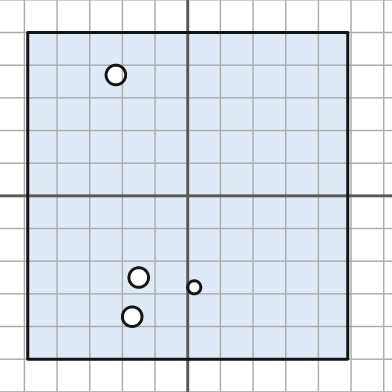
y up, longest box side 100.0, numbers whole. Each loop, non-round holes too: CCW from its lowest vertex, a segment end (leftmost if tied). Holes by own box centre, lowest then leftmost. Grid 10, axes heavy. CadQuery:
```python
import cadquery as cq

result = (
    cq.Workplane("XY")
    .moveTo(-49.0, -50.0)
    .lineTo(49.0, -50.0)
    .lineTo(49.0, 50.0)
    .lineTo(-49.0, 50.0)
    .close()
    .moveTo(-17.0, -37.0)
    .circle(3.0)
    .moveTo(2.0, -28.0)
    .circle(2.0)
    .moveTo(-15.0, -25.0)
    .circle(3.0)
    .moveTo(-22.0, 37.0)
    .circle(3.0)
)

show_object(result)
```